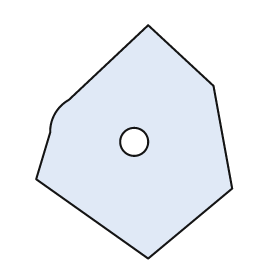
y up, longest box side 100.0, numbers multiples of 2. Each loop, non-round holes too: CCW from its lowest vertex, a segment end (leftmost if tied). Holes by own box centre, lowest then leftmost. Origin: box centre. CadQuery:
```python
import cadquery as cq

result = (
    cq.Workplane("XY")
    .moveTo(6.0, -50.0)
    .lineTo(42.0, -20.0)
    .lineTo(34.0, 24.0)
    .lineTo(6.0, 50.0)
    .lineTo(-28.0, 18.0)
    .threePointArc((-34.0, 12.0), (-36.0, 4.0))
    .lineTo(-42.0, -16.0)
    .close()
    .moveTo(0.0, 0.0)
    .circle(6.0)
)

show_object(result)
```